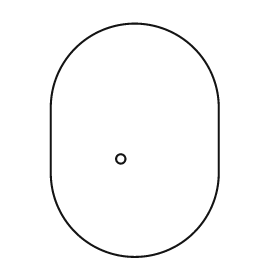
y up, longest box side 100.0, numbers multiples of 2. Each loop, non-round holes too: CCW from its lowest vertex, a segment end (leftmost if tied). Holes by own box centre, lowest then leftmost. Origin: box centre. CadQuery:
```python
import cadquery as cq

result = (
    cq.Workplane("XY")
    .moveTo(-36.0, -14.0)
    .threePointArc((0.0, -50.0), (36.0, -14.0))
    .lineTo(36.0, 14.0)
    .threePointArc((0.0, 50.0), (-36.0, 14.0))
    .close()
    .moveTo(-6.0, -8.0)
    .circle(2.0)
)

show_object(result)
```